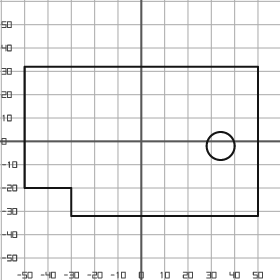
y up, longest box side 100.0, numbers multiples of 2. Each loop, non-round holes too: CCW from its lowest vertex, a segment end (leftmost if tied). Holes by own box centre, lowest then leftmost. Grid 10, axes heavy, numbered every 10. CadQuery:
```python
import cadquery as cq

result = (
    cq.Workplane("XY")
    .moveTo(-30.0, -32.0)
    .lineTo(50.0, -32.0)
    .lineTo(50.0, 32.0)
    .lineTo(-50.0, 32.0)
    .lineTo(-50.0, -20.0)
    .lineTo(-30.0, -20.0)
    .close()
    .moveTo(34.0, -2.0)
    .circle(6.0)
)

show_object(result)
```